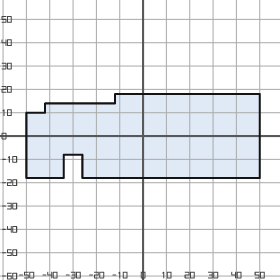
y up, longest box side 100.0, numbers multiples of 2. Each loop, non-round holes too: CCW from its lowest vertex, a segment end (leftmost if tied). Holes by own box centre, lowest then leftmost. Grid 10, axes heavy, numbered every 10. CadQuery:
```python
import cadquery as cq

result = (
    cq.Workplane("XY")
    .moveTo(-50.0, -18.0)
    .lineTo(-34.0, -18.0)
    .lineTo(-34.0, -8.0)
    .lineTo(-26.0, -8.0)
    .lineTo(-26.0, -18.0)
    .lineTo(50.0, -18.0)
    .lineTo(50.0, 18.0)
    .lineTo(-12.0, 18.0)
    .lineTo(-12.0, 14.0)
    .lineTo(-42.0, 14.0)
    .lineTo(-42.0, 10.0)
    .lineTo(-50.0, 10.0)
    .close()
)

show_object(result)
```